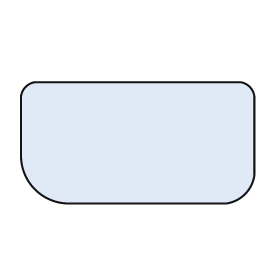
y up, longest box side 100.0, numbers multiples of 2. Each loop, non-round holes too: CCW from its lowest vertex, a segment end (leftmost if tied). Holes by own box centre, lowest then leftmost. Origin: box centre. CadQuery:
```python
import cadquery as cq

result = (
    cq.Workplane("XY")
    .moveTo(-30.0, -26.0)
    .lineTo(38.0, -26.0)
    .threePointArc((46.0, -22.0), (50.0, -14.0))
    .lineTo(50.0, 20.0)
    .threePointArc((48.0, 24.0), (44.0, 26.0))
    .lineTo(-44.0, 26.0)
    .threePointArc((-48.0, 24.0), (-50.0, 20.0))
    .lineTo(-50.0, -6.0)
    .threePointArc((-44.0, -20.0), (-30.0, -26.0))
    .close()
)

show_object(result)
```